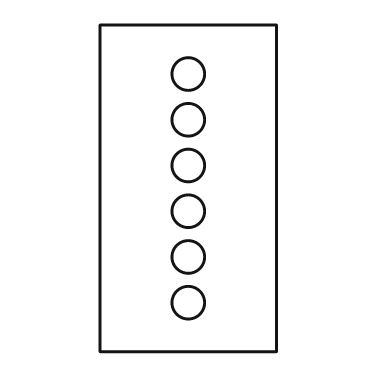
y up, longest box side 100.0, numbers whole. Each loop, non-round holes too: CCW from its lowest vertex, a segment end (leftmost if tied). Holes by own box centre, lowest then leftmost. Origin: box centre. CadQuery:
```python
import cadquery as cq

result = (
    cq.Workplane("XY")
    .moveTo(-27.0, -50.0)
    .lineTo(27.0, -50.0)
    .lineTo(27.0, 50.0)
    .lineTo(-27.0, 50.0)
    .close()
    .moveTo(0.0, -35.0)
    .circle(5.0)
    .moveTo(0.0, -21.0)
    .circle(5.0)
    .moveTo(0.0, -7.0)
    .circle(5.0)
    .moveTo(0.0, 7.0)
    .circle(5.0)
    .moveTo(0.0, 21.0)
    .circle(5.0)
    .moveTo(0.0, 35.0)
    .circle(5.0)
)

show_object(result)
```